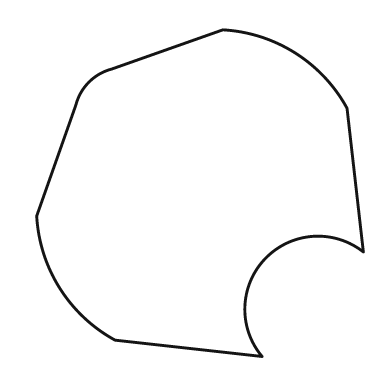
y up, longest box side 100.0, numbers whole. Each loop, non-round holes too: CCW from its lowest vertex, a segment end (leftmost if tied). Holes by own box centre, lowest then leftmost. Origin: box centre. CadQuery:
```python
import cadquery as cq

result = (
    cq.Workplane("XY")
    .moveTo(19.0, -50.0)
    .threePointArc((20.0, -20.0), (50.0, -18.0))
    .lineTo(45.0, 26.0)
    .threePointArc((29.0, 43.0), (7.0, 50.0))
    .lineTo(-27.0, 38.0)
    .threePointArc((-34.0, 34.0), (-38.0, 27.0))
    .lineTo(-50.0, -7.0)
    .threePointArc((-43.0, -29.0), (-26.0, -45.0))
    .close()
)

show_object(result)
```